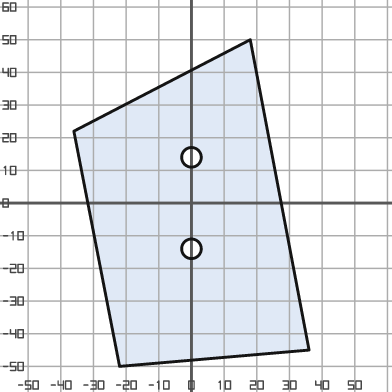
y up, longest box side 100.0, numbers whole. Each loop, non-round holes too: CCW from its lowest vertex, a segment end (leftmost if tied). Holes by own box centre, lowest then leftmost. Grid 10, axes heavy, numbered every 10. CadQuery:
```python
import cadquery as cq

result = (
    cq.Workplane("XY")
    .moveTo(-22.0, -50.0)
    .lineTo(36.0, -45.0)
    .lineTo(18.0, 50.0)
    .lineTo(-36.0, 22.0)
    .close()
    .moveTo(0.0, -14.0)
    .circle(3.0)
    .moveTo(0.0, 14.0)
    .circle(3.0)
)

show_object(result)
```